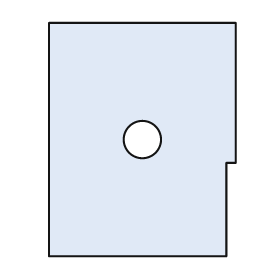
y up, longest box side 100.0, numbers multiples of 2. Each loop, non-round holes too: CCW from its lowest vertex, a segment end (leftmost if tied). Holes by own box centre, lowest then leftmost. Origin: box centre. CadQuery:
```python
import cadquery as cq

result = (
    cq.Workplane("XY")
    .moveTo(-40.0, -50.0)
    .lineTo(36.0, -50.0)
    .lineTo(36.0, -10.0)
    .lineTo(40.0, -10.0)
    .lineTo(40.0, 50.0)
    .lineTo(-40.0, 50.0)
    .close()
    .moveTo(0.0, 0.0)
    .circle(8.0)
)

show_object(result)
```